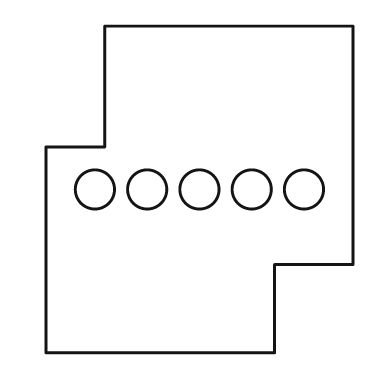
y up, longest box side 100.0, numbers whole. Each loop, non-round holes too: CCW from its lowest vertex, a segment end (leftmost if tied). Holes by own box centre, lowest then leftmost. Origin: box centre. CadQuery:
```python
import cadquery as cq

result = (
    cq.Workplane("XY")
    .moveTo(-47.0, -50.0)
    .lineTo(23.0, -50.0)
    .lineTo(23.0, -23.0)
    .lineTo(47.0, -23.0)
    .lineTo(47.0, 50.0)
    .lineTo(-29.0, 50.0)
    .lineTo(-29.0, 13.0)
    .lineTo(-47.0, 13.0)
    .close()
    .moveTo(-32.0, 0.0)
    .circle(6.0)
    .moveTo(-16.0, 0.0)
    .circle(6.0)
    .moveTo(0.0, 0.0)
    .circle(6.0)
    .moveTo(16.0, 0.0)
    .circle(6.0)
    .moveTo(32.0, 0.0)
    .circle(6.0)
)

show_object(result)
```